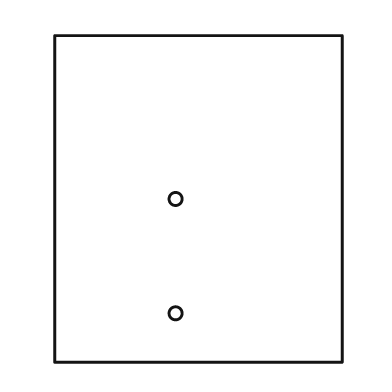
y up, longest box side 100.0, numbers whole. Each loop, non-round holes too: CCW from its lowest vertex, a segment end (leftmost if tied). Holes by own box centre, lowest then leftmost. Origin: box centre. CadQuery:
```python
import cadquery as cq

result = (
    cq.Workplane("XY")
    .moveTo(-44.0, -50.0)
    .lineTo(44.0, -50.0)
    .lineTo(44.0, 50.0)
    .lineTo(-44.0, 50.0)
    .close()
    .moveTo(-7.0, -35.0)
    .circle(2.0)
    .moveTo(-7.0, 0.0)
    .circle(2.0)
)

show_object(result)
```